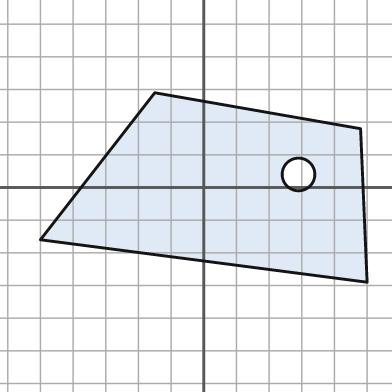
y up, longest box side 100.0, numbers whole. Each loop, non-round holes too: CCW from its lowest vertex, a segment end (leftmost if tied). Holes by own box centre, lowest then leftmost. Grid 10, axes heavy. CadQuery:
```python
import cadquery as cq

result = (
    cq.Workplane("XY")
    .moveTo(50.0, -29.0)
    .lineTo(48.0, 18.0)
    .lineTo(-15.0, 29.0)
    .lineTo(-50.0, -16.0)
    .close()
    .moveTo(29.0, 4.0)
    .circle(5.0)
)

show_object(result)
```